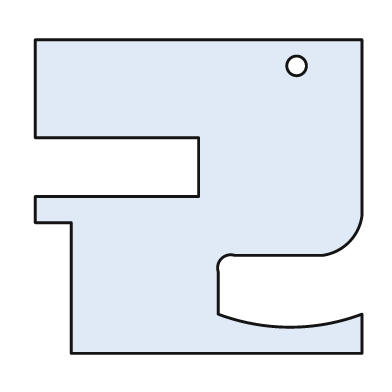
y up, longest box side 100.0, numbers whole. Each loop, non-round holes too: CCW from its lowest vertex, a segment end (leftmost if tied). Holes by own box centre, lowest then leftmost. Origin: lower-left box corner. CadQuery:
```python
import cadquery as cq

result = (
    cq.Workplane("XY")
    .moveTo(11.0, 0.0)
    .lineTo(100.0, 0.0)
    .lineTo(100.0, 12.0)
    .threePointArc((78.0, 8.0), (56.0, 12.0))
    .lineTo(56.0, 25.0)
    .threePointArc((57.0, 29.0), (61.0, 30.0))
    .lineTo(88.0, 30.0)
    .threePointArc((96.0, 34.0), (100.0, 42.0))
    .lineTo(100.0, 96.0)
    .lineTo(0.0, 96.0)
    .lineTo(0.0, 66.0)
    .lineTo(50.0, 66.0)
    .lineTo(50.0, 48.0)
    .lineTo(0.0, 48.0)
    .lineTo(0.0, 40.0)
    .lineTo(11.0, 40.0)
    .close()
    .moveTo(80.0, 88.0)
    .circle(3.0)
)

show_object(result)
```